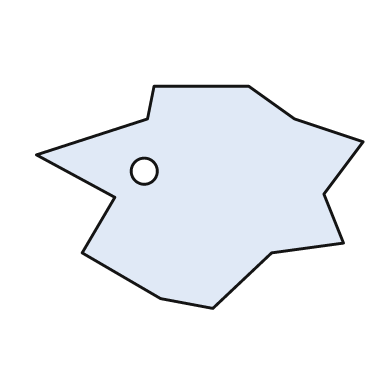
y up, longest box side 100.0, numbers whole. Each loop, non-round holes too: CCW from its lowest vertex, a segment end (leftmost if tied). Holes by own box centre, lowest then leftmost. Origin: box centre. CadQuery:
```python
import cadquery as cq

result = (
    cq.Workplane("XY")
    .moveTo(4.0, -34.0)
    .lineTo(22.0, -17.0)
    .lineTo(44.0, -14.0)
    .lineTo(38.0, 1.0)
    .lineTo(50.0, 17.0)
    .lineTo(29.0, 24.0)
    .lineTo(15.0, 34.0)
    .lineTo(-14.0, 34.0)
    .lineTo(-16.0, 24.0)
    .lineTo(-50.0, 13.0)
    .lineTo(-26.0, 0.0)
    .lineTo(-36.0, -17.0)
    .lineTo(-12.0, -31.0)
    .close()
    .moveTo(-17.0, 8.0)
    .circle(4.0)
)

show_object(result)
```